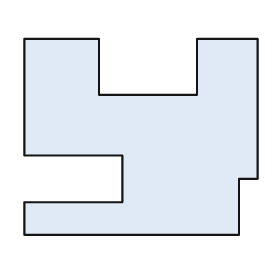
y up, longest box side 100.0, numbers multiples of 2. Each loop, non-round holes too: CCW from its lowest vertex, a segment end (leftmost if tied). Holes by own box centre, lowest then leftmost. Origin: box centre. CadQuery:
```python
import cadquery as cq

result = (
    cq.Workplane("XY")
    .moveTo(-50.0, -42.0)
    .lineTo(42.0, -42.0)
    .lineTo(42.0, -18.0)
    .lineTo(50.0, -18.0)
    .lineTo(50.0, 42.0)
    .lineTo(24.0, 42.0)
    .lineTo(24.0, 18.0)
    .lineTo(-18.0, 18.0)
    .lineTo(-18.0, 42.0)
    .lineTo(-50.0, 42.0)
    .lineTo(-50.0, -8.0)
    .lineTo(-8.0, -8.0)
    .lineTo(-8.0, -28.0)
    .lineTo(-50.0, -28.0)
    .close()
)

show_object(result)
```